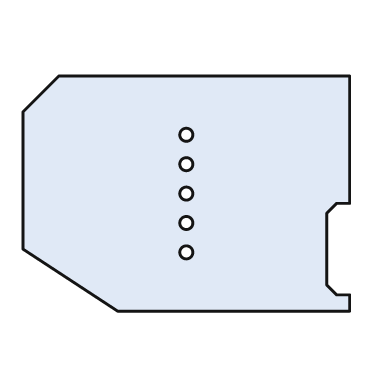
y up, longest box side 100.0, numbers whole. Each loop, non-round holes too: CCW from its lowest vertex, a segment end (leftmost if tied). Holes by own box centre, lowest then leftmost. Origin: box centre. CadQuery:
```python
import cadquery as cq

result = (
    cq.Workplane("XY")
    .moveTo(-21.0, -36.0)
    .lineTo(50.0, -36.0)
    .lineTo(50.0, -31.0)
    .lineTo(46.0, -31.0)
    .lineTo(43.0, -28.0)
    .lineTo(43.0, -6.0)
    .lineTo(46.0, -3.0)
    .lineTo(50.0, -3.0)
    .lineTo(50.0, 36.0)
    .lineTo(-39.0, 36.0)
    .lineTo(-50.0, 25.0)
    .lineTo(-50.0, -17.0)
    .close()
    .moveTo(0.0, -18.0)
    .circle(2.0)
    .moveTo(0.0, -9.0)
    .circle(2.0)
    .moveTo(0.0, 0.0)
    .circle(2.0)
    .moveTo(0.0, 9.0)
    .circle(2.0)
    .moveTo(0.0, 18.0)
    .circle(2.0)
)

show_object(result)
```